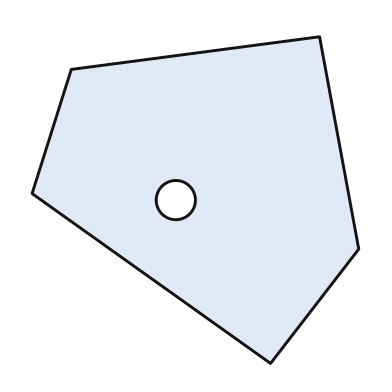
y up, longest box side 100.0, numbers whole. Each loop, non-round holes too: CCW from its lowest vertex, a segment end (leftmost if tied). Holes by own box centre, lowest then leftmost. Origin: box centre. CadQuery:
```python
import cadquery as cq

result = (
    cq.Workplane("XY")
    .moveTo(23.0, -50.0)
    .lineTo(50.0, -15.0)
    .lineTo(38.0, 50.0)
    .lineTo(-38.0, 40.0)
    .lineTo(-50.0, 2.0)
    .close()
    .moveTo(-6.0, 0.0)
    .circle(6.0)
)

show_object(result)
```